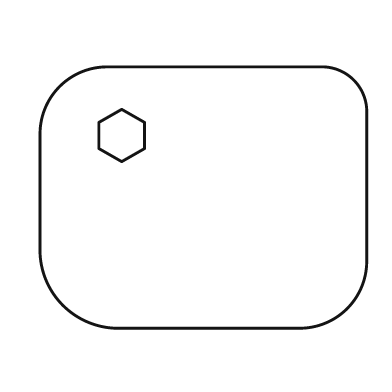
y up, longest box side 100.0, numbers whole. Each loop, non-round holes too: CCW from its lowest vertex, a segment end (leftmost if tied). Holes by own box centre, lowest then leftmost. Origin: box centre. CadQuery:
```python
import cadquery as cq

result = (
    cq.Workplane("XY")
    .moveTo(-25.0, -40.0)
    .lineTo(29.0, -40.0)
    .threePointArc((44.0, -34.0), (50.0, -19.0))
    .lineTo(50.0, 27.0)
    .threePointArc((46.0, 36.0), (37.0, 40.0))
    .lineTo(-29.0, 40.0)
    .threePointArc((-44.0, 34.0), (-50.0, 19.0))
    .lineTo(-50.0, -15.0)
    .threePointArc((-43.0, -33.0), (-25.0, -40.0))
    .close()
    .moveTo(-25.0, 11.0)
    .lineTo(-18.0, 15.0)
    .lineTo(-18.0, 23.0)
    .lineTo(-25.0, 27.0)
    .lineTo(-32.0, 23.0)
    .lineTo(-32.0, 15.0)
    .close()
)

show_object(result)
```